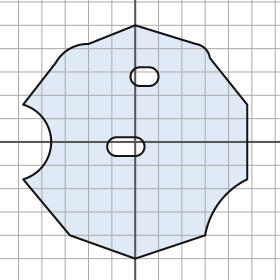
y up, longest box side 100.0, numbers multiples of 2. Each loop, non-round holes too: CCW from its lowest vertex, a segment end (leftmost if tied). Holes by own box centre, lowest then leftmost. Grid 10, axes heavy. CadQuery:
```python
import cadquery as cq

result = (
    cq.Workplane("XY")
    .moveTo(0.0, -50.0)
    .lineTo(30.0, -40.0)
    .threePointArc((36.0, -26.0), (48.0, -16.0))
    .lineTo(48.0, 16.0)
    .lineTo(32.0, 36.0)
    .threePointArc((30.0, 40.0), (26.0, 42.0))
    .lineTo(0.0, 50.0)
    .lineTo(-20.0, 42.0)
    .threePointArc((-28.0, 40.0), (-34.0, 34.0))
    .lineTo(-48.0, 16.0)
    .threePointArc((-36.0, 0.0), (-48.0, -16.0))
    .lineTo(-28.0, -40.0)
    .close()
    .moveTo(-8.0, -6.0)
    .lineTo(0.0, -6.0)
    .threePointArc((4.0, -2.0), (0.0, 2.0))
    .lineTo(-8.0, 2.0)
    .threePointArc((-12.0, -2.0), (-8.0, -6.0))
    .close()
    .moveTo(2.0, 24.0)
    .lineTo(6.0, 24.0)
    .threePointArc((10.0, 28.0), (6.0, 32.0))
    .lineTo(2.0, 32.0)
    .threePointArc((-2.0, 28.0), (2.0, 24.0))
    .close()
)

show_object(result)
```